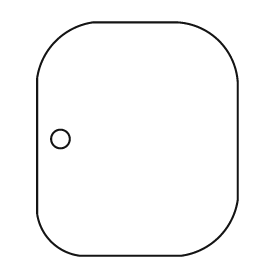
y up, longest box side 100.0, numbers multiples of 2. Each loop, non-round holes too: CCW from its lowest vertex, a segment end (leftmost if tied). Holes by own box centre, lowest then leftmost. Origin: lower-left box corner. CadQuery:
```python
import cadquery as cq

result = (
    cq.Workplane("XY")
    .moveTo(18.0, 0.0)
    .lineTo(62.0, 0.0)
    .threePointArc((78.0, 8.0), (86.0, 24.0))
    .lineTo(86.0, 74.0)
    .threePointArc((78.0, 92.0), (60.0, 100.0))
    .lineTo(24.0, 100.0)
    .threePointArc((8.0, 92.0), (0.0, 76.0))
    .lineTo(0.0, 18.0)
    .threePointArc((6.0, 6.0), (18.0, 0.0))
    .close()
    .moveTo(10.0, 50.0)
    .circle(4.0)
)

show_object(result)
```